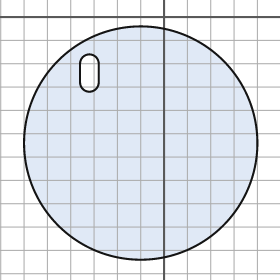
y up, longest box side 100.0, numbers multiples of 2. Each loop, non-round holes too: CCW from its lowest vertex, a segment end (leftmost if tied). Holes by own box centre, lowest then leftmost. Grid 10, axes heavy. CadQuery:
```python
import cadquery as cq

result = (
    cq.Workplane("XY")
    .moveTo(-10.0, -54.0)
    .circle(50.0)
    .moveTo(-36.0, -28.0)
    .threePointArc((-32.0, -32.0), (-28.0, -28.0))
    .lineTo(-28.0, -20.0)
    .threePointArc((-32.0, -16.0), (-36.0, -20.0))
    .close()
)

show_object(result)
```